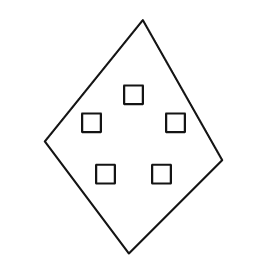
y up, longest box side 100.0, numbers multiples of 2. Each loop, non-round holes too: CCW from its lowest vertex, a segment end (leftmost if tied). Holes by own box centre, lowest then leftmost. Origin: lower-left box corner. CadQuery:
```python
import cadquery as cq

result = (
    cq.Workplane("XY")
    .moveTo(36.0, 0.0)
    .lineTo(76.0, 40.0)
    .lineTo(42.0, 100.0)
    .lineTo(0.0, 48.0)
    .close()
    .moveTo(22.0, 30.0)
    .lineTo(30.0, 30.0)
    .lineTo(30.0, 38.0)
    .lineTo(22.0, 38.0)
    .close()
    .moveTo(46.0, 30.0)
    .lineTo(54.0, 30.0)
    .lineTo(54.0, 38.0)
    .lineTo(46.0, 38.0)
    .close()
    .moveTo(16.0, 52.0)
    .lineTo(24.0, 52.0)
    .lineTo(24.0, 60.0)
    .lineTo(16.0, 60.0)
    .close()
    .moveTo(52.0, 52.0)
    .lineTo(60.0, 52.0)
    .lineTo(60.0, 60.0)
    .lineTo(52.0, 60.0)
    .close()
    .moveTo(34.0, 64.0)
    .lineTo(42.0, 64.0)
    .lineTo(42.0, 72.0)
    .lineTo(34.0, 72.0)
    .close()
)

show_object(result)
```